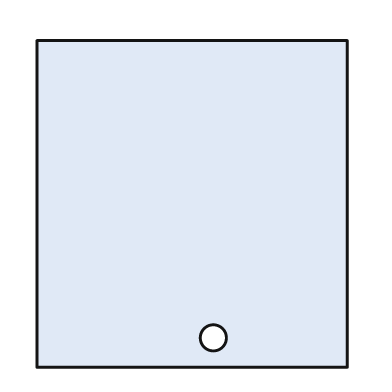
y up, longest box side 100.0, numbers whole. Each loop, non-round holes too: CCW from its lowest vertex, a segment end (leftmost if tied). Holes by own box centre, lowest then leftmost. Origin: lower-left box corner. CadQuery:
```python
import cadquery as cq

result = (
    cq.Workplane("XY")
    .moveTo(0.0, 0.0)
    .lineTo(95.0, 0.0)
    .lineTo(95.0, 100.0)
    .lineTo(0.0, 100.0)
    .close()
    .moveTo(54.0, 9.0)
    .circle(4.0)
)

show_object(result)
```